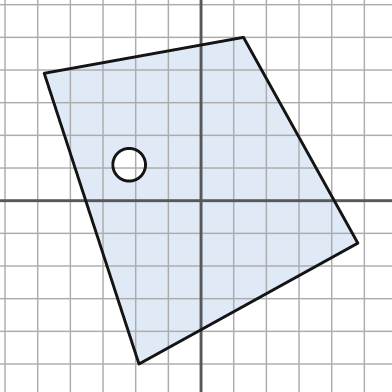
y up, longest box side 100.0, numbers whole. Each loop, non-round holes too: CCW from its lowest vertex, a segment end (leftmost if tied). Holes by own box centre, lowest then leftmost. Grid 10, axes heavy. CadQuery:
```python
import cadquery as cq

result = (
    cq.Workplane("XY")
    .moveTo(-19.0, -50.0)
    .lineTo(48.0, -13.0)
    .lineTo(13.0, 50.0)
    .lineTo(-48.0, 39.0)
    .close()
    .moveTo(-22.0, 11.0)
    .circle(5.0)
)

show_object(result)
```